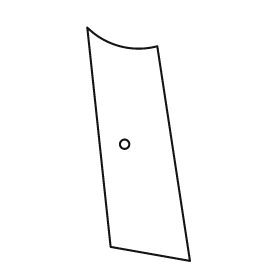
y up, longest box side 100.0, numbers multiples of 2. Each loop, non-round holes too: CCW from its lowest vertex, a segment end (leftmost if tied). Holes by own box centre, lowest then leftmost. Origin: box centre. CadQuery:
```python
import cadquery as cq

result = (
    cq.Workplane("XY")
    .moveTo(22.0, -50.0)
    .lineTo(8.0, 42.0)
    .threePointArc((-8.0, 42.0), (-22.0, 50.0))
    .lineTo(-12.0, -44.0)
    .close()
    .moveTo(-6.0, 0.0)
    .circle(2.0)
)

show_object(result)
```